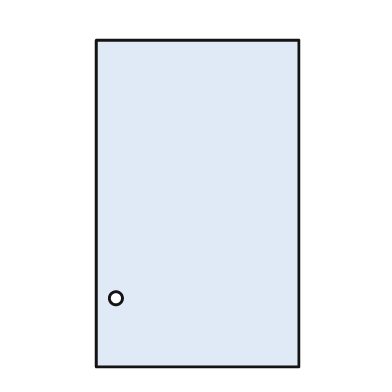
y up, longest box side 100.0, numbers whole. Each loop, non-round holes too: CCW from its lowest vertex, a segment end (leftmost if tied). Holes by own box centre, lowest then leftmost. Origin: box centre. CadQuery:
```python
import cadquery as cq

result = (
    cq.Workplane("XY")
    .moveTo(-31.0, -50.0)
    .lineTo(31.0, -50.0)
    .lineTo(31.0, 50.0)
    .lineTo(-31.0, 50.0)
    .close()
    .moveTo(-25.0, -29.0)
    .circle(2.0)
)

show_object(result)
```